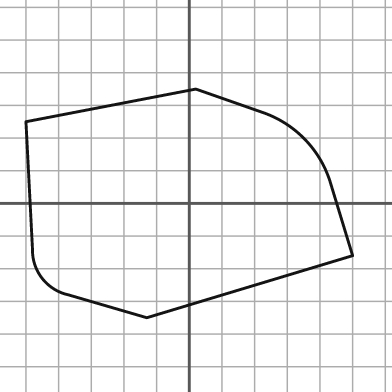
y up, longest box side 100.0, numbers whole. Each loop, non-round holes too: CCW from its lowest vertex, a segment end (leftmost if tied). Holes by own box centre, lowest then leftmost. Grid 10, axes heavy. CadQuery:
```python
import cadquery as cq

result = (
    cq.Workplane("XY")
    .moveTo(-13.0, -35.0)
    .lineTo(50.0, -16.0)
    .lineTo(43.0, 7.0)
    .threePointArc((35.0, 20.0), (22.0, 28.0))
    .lineTo(2.0, 35.0)
    .lineTo(-50.0, 25.0)
    .lineTo(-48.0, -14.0)
    .threePointArc((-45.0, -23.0), (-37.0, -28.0))
    .close()
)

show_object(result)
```